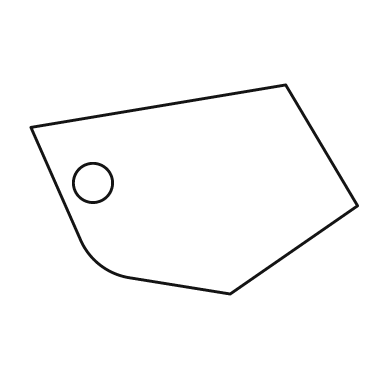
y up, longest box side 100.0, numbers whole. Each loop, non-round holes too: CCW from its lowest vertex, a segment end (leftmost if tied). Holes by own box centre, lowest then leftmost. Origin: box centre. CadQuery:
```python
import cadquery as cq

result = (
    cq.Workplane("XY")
    .moveTo(11.0, -32.0)
    .lineTo(50.0, -5.0)
    .lineTo(28.0, 32.0)
    .lineTo(-50.0, 19.0)
    .lineTo(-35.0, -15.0)
    .threePointArc((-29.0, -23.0), (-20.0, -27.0))
    .close()
    .moveTo(-31.0, 2.0)
    .circle(6.0)
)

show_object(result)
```